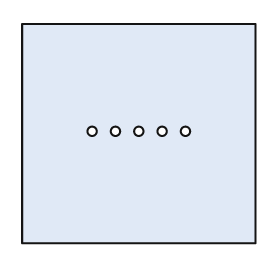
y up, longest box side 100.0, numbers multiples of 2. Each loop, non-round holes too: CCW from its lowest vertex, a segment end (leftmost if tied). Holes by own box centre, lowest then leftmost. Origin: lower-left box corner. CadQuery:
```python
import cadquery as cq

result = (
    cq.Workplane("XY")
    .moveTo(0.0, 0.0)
    .lineTo(100.0, 0.0)
    .lineTo(100.0, 94.0)
    .lineTo(0.0, 94.0)
    .close()
    .moveTo(30.0, 48.0)
    .circle(2.0)
    .moveTo(40.0, 48.0)
    .circle(2.0)
    .moveTo(50.0, 48.0)
    .circle(2.0)
    .moveTo(60.0, 48.0)
    .circle(2.0)
    .moveTo(70.0, 48.0)
    .circle(2.0)
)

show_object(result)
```